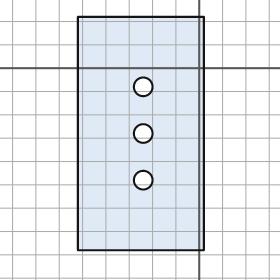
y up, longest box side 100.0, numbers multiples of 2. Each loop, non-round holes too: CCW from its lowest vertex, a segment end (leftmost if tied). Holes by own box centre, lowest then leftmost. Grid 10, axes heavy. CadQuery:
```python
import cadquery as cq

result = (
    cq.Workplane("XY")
    .moveTo(-52.0, -78.0)
    .lineTo(2.0, -78.0)
    .lineTo(2.0, 22.0)
    .lineTo(-52.0, 22.0)
    .close()
    .moveTo(-24.0, -48.0)
    .circle(4.0)
    .moveTo(-24.0, -28.0)
    .circle(4.0)
    .moveTo(-24.0, -8.0)
    .circle(4.0)
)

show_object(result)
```